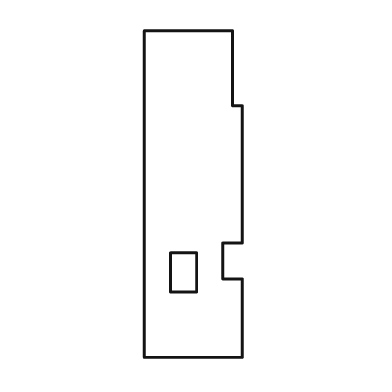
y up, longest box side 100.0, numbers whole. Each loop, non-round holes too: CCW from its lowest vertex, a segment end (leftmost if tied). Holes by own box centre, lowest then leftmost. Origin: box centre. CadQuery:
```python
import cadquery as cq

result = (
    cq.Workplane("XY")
    .moveTo(-15.0, -50.0)
    .lineTo(15.0, -50.0)
    .lineTo(15.0, -26.0)
    .lineTo(9.0, -26.0)
    .lineTo(9.0, -15.0)
    .lineTo(15.0, -15.0)
    .lineTo(15.0, 27.0)
    .lineTo(12.0, 27.0)
    .lineTo(12.0, 50.0)
    .lineTo(-15.0, 50.0)
    .close()
    .moveTo(-7.0, -30.0)
    .lineTo(1.0, -30.0)
    .lineTo(1.0, -18.0)
    .lineTo(-7.0, -18.0)
    .close()
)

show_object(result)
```